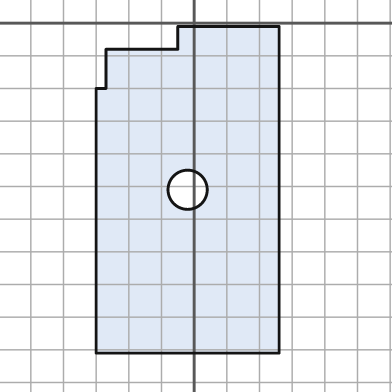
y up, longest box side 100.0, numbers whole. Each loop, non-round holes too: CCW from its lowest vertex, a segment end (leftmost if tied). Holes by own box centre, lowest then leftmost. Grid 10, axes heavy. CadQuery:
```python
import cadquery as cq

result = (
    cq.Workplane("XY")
    .moveTo(-30.0, -101.0)
    .lineTo(26.0, -101.0)
    .lineTo(26.0, -1.0)
    .lineTo(-5.0, -1.0)
    .lineTo(-5.0, -8.0)
    .lineTo(-27.0, -8.0)
    .lineTo(-27.0, -20.0)
    .lineTo(-30.0, -20.0)
    .close()
    .moveTo(-2.0, -51.0)
    .circle(6.0)
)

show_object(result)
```